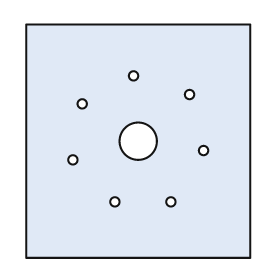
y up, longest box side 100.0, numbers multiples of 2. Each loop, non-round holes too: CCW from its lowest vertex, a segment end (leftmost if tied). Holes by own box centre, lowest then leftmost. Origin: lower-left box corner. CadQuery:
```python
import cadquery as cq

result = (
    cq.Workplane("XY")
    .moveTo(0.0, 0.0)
    .lineTo(96.0, 0.0)
    .lineTo(96.0, 100.0)
    .lineTo(0.0, 100.0)
    .close()
    .moveTo(38.0, 24.0)
    .circle(2.0)
    .moveTo(62.0, 24.0)
    .circle(2.0)
    .moveTo(20.0, 42.0)
    .circle(2.0)
    .moveTo(76.0, 46.0)
    .circle(2.0)
    .moveTo(48.0, 50.0)
    .circle(8.0)
    .moveTo(24.0, 66.0)
    .circle(2.0)
    .moveTo(70.0, 70.0)
    .circle(2.0)
    .moveTo(46.0, 78.0)
    .circle(2.0)
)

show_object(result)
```